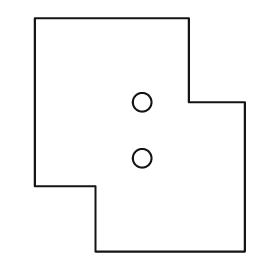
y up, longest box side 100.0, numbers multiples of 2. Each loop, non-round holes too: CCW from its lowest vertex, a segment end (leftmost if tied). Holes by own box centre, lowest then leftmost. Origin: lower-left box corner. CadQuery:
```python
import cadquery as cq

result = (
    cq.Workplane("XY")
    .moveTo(26.0, 0.0)
    .lineTo(90.0, 0.0)
    .lineTo(90.0, 64.0)
    .lineTo(66.0, 64.0)
    .lineTo(66.0, 100.0)
    .lineTo(0.0, 100.0)
    .lineTo(0.0, 28.0)
    .lineTo(26.0, 28.0)
    .close()
    .moveTo(46.0, 40.0)
    .circle(4.0)
    .moveTo(46.0, 64.0)
    .circle(4.0)
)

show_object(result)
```